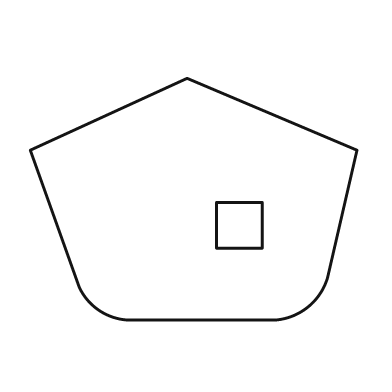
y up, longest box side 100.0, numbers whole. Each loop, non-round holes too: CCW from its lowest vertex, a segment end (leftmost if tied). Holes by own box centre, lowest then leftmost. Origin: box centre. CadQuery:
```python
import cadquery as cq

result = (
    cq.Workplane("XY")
    .moveTo(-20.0, -37.0)
    .lineTo(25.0, -37.0)
    .threePointArc((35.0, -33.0), (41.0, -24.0))
    .lineTo(50.0, 15.0)
    .lineTo(-2.0, 37.0)
    .lineTo(-50.0, 15.0)
    .lineTo(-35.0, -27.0)
    .threePointArc((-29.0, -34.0), (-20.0, -37.0))
    .close()
    .moveTo(7.0, -15.0)
    .lineTo(21.0, -15.0)
    .lineTo(21.0, -1.0)
    .lineTo(7.0, -1.0)
    .close()
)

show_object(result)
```